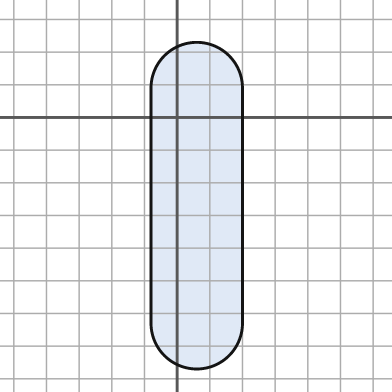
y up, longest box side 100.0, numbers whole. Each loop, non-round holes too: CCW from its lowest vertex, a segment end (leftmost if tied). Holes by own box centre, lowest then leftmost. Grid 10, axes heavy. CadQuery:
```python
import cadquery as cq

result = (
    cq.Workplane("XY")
    .moveTo(-8.0, -63.0)
    .threePointArc((6.0, -77.0), (20.0, -63.0))
    .lineTo(20.0, 9.0)
    .threePointArc((6.0, 23.0), (-8.0, 9.0))
    .close()
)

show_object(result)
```